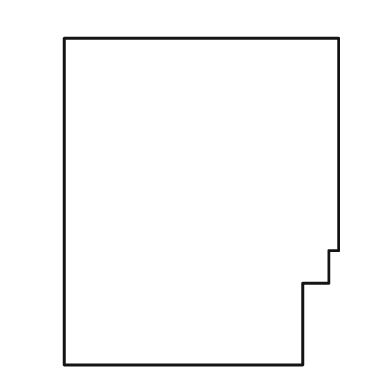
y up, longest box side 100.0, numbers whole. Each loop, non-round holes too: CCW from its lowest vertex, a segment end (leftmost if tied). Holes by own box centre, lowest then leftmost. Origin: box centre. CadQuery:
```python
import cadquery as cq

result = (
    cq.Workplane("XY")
    .moveTo(-42.0, -50.0)
    .lineTo(31.0, -50.0)
    .lineTo(31.0, -25.0)
    .lineTo(39.0, -25.0)
    .lineTo(39.0, -15.0)
    .lineTo(42.0, -15.0)
    .lineTo(42.0, 50.0)
    .lineTo(-42.0, 50.0)
    .close()
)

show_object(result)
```